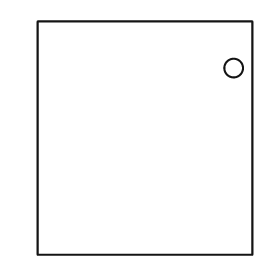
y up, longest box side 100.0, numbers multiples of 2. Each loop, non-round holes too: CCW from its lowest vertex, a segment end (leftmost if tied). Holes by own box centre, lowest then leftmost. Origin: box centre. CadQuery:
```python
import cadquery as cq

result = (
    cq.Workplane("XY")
    .moveTo(-46.0, -50.0)
    .lineTo(46.0, -50.0)
    .lineTo(46.0, 50.0)
    .lineTo(-46.0, 50.0)
    .close()
    .moveTo(38.0, 30.0)
    .circle(4.0)
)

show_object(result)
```